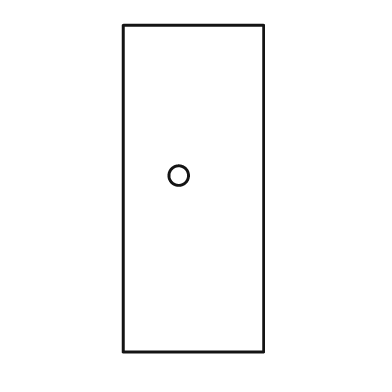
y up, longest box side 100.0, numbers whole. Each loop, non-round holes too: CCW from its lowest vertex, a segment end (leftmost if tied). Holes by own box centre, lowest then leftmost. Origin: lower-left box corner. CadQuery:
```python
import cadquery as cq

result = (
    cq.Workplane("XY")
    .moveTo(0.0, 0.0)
    .lineTo(43.0, 0.0)
    .lineTo(43.0, 100.0)
    .lineTo(0.0, 100.0)
    .close()
    .moveTo(17.0, 54.0)
    .circle(3.0)
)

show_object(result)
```